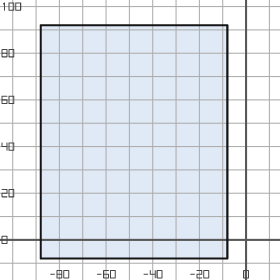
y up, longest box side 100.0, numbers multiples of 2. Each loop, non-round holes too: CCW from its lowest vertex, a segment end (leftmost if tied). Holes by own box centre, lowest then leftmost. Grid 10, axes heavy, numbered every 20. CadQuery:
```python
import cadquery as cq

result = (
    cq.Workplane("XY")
    .moveTo(-88.0, -8.0)
    .lineTo(-8.0, -8.0)
    .lineTo(-8.0, 92.0)
    .lineTo(-88.0, 92.0)
    .close()
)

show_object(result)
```